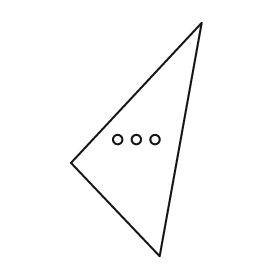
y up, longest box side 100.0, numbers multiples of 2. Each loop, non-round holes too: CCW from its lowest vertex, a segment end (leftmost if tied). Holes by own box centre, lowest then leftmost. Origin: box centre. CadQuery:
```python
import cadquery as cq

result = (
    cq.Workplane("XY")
    .moveTo(10.0, -50.0)
    .lineTo(28.0, 50.0)
    .lineTo(-28.0, -10.0)
    .close()
    .moveTo(-8.0, 0.0)
    .circle(2.0)
    .moveTo(0.0, 0.0)
    .circle(2.0)
    .moveTo(8.0, 0.0)
    .circle(2.0)
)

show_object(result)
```